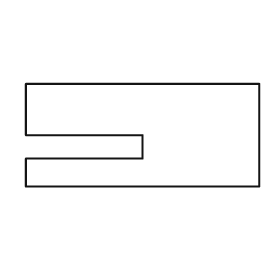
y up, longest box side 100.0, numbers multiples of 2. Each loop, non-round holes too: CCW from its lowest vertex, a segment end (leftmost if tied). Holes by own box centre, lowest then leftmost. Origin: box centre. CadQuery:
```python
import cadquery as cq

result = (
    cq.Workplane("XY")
    .moveTo(-50.0, -22.0)
    .lineTo(50.0, -22.0)
    .lineTo(50.0, 22.0)
    .lineTo(-50.0, 22.0)
    .lineTo(-50.0, 0.0)
    .lineTo(0.0, 0.0)
    .lineTo(0.0, -10.0)
    .lineTo(-50.0, -10.0)
    .close()
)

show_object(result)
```